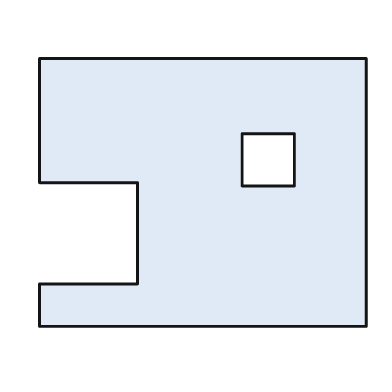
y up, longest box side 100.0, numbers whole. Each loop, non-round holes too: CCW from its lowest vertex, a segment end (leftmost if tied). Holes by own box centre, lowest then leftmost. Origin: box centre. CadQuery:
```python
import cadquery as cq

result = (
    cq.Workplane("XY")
    .moveTo(-50.0, -41.0)
    .lineTo(50.0, -41.0)
    .lineTo(50.0, 41.0)
    .lineTo(-50.0, 41.0)
    .lineTo(-50.0, 3.0)
    .lineTo(-20.0, 3.0)
    .lineTo(-20.0, -28.0)
    .lineTo(-50.0, -28.0)
    .close()
    .moveTo(12.0, 2.0)
    .lineTo(28.0, 2.0)
    .lineTo(28.0, 18.0)
    .lineTo(12.0, 18.0)
    .close()
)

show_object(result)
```